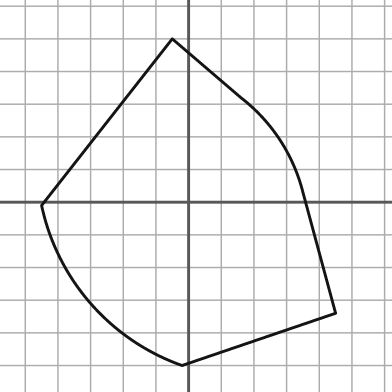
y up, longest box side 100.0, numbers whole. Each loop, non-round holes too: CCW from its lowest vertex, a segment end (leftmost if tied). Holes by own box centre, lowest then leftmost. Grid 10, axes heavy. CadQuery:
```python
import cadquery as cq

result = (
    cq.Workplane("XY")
    .moveTo(-2.0, -50.0)
    .lineTo(45.0, -34.0)
    .lineTo(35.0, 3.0)
    .threePointArc((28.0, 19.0), (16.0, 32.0))
    .lineTo(-5.0, 50.0)
    .lineTo(-45.0, -1.0)
    .threePointArc((-30.0, -31.0), (-2.0, -50.0))
    .close()
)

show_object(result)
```